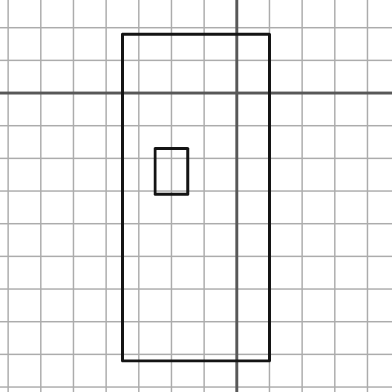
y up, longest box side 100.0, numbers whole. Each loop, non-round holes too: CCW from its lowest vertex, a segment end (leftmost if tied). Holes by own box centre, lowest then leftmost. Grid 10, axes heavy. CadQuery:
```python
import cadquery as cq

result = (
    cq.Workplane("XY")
    .moveTo(-35.0, -82.0)
    .lineTo(10.0, -82.0)
    .lineTo(10.0, 18.0)
    .lineTo(-35.0, 18.0)
    .close()
    .moveTo(-25.0, -31.0)
    .lineTo(-15.0, -31.0)
    .lineTo(-15.0, -17.0)
    .lineTo(-25.0, -17.0)
    .close()
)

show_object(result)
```